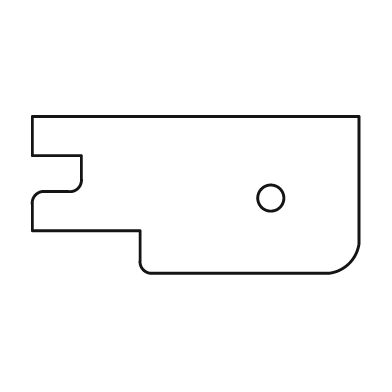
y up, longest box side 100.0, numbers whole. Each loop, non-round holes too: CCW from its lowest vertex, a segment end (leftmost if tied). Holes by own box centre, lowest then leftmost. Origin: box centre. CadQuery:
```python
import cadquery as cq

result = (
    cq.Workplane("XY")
    .moveTo(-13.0, -24.0)
    .lineTo(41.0, -24.0)
    .threePointArc((47.0, -21.0), (50.0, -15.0))
    .lineTo(50.0, 24.0)
    .lineTo(-50.0, 24.0)
    .lineTo(-50.0, 12.0)
    .lineTo(-35.0, 12.0)
    .lineTo(-35.0, 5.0)
    .threePointArc((-36.0, 2.0), (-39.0, 1.0))
    .lineTo(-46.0, 1.0)
    .threePointArc((-49.0, 0.0), (-50.0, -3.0))
    .lineTo(-50.0, -11.0)
    .lineTo(-17.0, -11.0)
    .lineTo(-17.0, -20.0)
    .threePointArc((-16.0, -23.0), (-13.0, -24.0))
    .close()
    .moveTo(23.0, -1.0)
    .circle(4.0)
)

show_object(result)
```